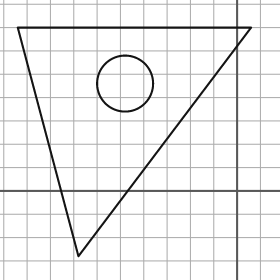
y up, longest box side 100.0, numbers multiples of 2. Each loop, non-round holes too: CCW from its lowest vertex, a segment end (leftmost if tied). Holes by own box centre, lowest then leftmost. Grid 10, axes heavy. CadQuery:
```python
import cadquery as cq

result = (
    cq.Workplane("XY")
    .moveTo(-68.0, -28.0)
    .lineTo(6.0, 70.0)
    .lineTo(-94.0, 70.0)
    .close()
    .moveTo(-48.0, 46.0)
    .circle(12.0)
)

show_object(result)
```